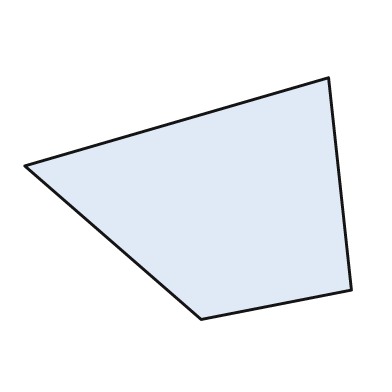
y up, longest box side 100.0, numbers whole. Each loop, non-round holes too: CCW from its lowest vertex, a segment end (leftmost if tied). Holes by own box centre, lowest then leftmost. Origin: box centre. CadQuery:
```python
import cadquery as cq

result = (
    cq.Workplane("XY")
    .moveTo(4.0, -37.0)
    .lineTo(50.0, -28.0)
    .lineTo(43.0, 37.0)
    .lineTo(-50.0, 10.0)
    .close()
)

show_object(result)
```